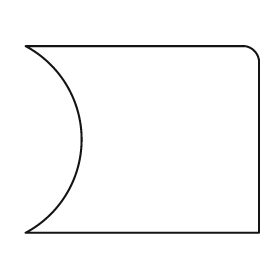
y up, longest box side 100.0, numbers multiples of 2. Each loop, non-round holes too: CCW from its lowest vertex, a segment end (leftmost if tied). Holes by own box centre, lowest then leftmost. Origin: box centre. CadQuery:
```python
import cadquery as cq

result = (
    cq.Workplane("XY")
    .moveTo(-50.0, -40.0)
    .lineTo(50.0, -40.0)
    .lineTo(50.0, 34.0)
    .threePointArc((48.0, 38.0), (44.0, 40.0))
    .lineTo(-50.0, 40.0)
    .threePointArc((-26.0, 0.0), (-50.0, -40.0))
    .close()
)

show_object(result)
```